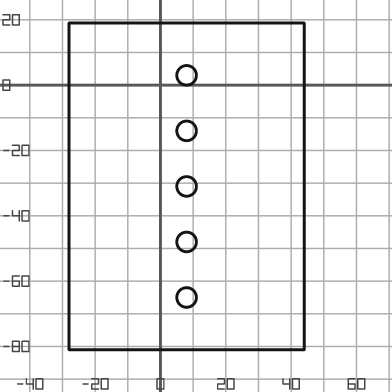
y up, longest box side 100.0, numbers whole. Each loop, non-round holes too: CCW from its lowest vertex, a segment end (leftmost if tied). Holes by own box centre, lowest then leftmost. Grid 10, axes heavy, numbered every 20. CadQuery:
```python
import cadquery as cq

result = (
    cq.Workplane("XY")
    .moveTo(-28.0, -81.0)
    .lineTo(44.0, -81.0)
    .lineTo(44.0, 19.0)
    .lineTo(-28.0, 19.0)
    .close()
    .moveTo(8.0, -65.0)
    .circle(3.0)
    .moveTo(8.0, -48.0)
    .circle(3.0)
    .moveTo(8.0, -31.0)
    .circle(3.0)
    .moveTo(8.0, -14.0)
    .circle(3.0)
    .moveTo(8.0, 3.0)
    .circle(3.0)
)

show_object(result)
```